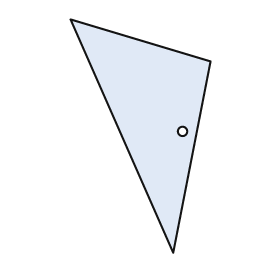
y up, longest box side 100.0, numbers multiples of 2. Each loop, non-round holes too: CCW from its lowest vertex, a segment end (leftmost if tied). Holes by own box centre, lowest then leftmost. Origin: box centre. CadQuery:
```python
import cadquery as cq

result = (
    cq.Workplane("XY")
    .moveTo(14.0, -50.0)
    .lineTo(30.0, 32.0)
    .lineTo(-30.0, 50.0)
    .close()
    .moveTo(18.0, 2.0)
    .circle(2.0)
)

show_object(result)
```